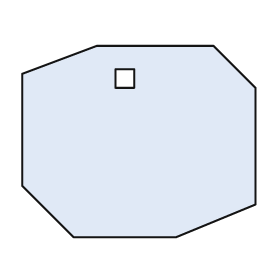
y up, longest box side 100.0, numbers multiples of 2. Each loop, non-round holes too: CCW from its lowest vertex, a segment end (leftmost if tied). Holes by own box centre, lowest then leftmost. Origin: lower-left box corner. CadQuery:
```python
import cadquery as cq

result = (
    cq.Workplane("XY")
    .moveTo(22.0, 0.0)
    .lineTo(66.0, 0.0)
    .lineTo(100.0, 14.0)
    .lineTo(100.0, 64.0)
    .lineTo(82.0, 82.0)
    .lineTo(32.0, 82.0)
    .lineTo(0.0, 70.0)
    .lineTo(0.0, 22.0)
    .close()
    .moveTo(40.0, 64.0)
    .lineTo(48.0, 64.0)
    .lineTo(48.0, 72.0)
    .lineTo(40.0, 72.0)
    .close()
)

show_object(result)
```